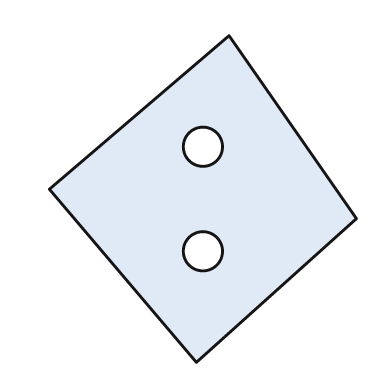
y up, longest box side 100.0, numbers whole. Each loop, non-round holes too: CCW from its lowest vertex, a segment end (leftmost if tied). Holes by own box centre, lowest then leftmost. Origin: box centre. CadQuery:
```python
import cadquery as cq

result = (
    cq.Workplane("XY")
    .moveTo(-2.0, -50.0)
    .lineTo(47.0, -6.0)
    .lineTo(8.0, 50.0)
    .lineTo(-47.0, 3.0)
    .close()
    .moveTo(0.0, -16.0)
    .circle(6.0)
    .moveTo(0.0, 16.0)
    .circle(6.0)
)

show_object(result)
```